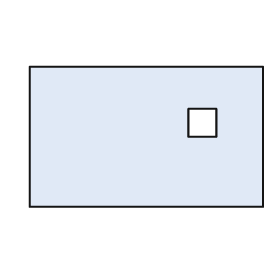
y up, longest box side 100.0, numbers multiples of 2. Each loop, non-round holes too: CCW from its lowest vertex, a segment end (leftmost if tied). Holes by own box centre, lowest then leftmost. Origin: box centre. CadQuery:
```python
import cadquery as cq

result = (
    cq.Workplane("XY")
    .moveTo(-50.0, -30.0)
    .lineTo(50.0, -30.0)
    .lineTo(50.0, 30.0)
    .lineTo(-50.0, 30.0)
    .close()
    .moveTo(18.0, 0.0)
    .lineTo(30.0, 0.0)
    .lineTo(30.0, 12.0)
    .lineTo(18.0, 12.0)
    .close()
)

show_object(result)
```